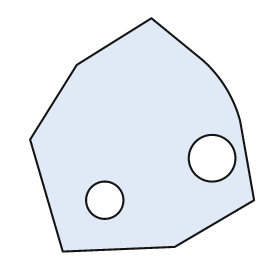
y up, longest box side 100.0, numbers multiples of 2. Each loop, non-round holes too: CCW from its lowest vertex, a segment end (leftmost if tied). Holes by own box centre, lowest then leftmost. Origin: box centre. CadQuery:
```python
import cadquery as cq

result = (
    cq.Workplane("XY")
    .moveTo(-34.0, -50.0)
    .lineTo(14.0, -48.0)
    .lineTo(48.0, -28.0)
    .lineTo(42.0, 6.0)
    .threePointArc((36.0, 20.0), (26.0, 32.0))
    .lineTo(4.0, 50.0)
    .lineTo(-28.0, 30.0)
    .lineTo(-48.0, -2.0)
    .close()
    .moveTo(-16.0, -28.0)
    .circle(8.0)
    .moveTo(30.0, -10.0)
    .circle(10.0)
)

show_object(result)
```